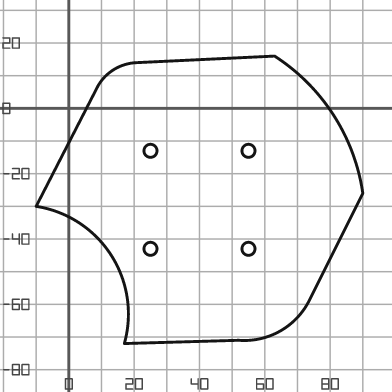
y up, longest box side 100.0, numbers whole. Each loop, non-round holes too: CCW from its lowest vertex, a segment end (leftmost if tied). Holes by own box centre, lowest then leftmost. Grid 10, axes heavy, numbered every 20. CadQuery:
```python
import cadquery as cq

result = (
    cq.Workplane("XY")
    .moveTo(17.0, -72.0)
    .lineTo(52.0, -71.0)
    .threePointArc((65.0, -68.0), (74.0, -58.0))
    .lineTo(90.0, -26.0)
    .threePointArc((81.0, -2.0), (63.0, 16.0))
    .lineTo(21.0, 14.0)
    .threePointArc((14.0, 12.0), (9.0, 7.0))
    .lineTo(-10.0, -30.0)
    .threePointArc((13.0, -45.0), (17.0, -72.0))
    .close()
    .moveTo(25.0, -43.0)
    .circle(2.0)
    .moveTo(55.0, -43.0)
    .circle(2.0)
    .moveTo(25.0, -13.0)
    .circle(2.0)
    .moveTo(55.0, -13.0)
    .circle(2.0)
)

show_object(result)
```